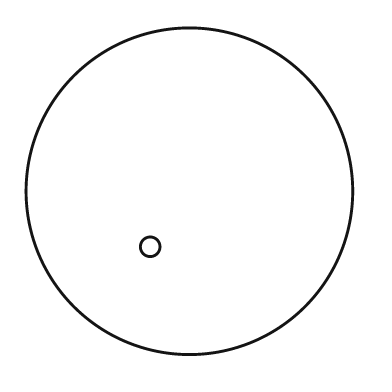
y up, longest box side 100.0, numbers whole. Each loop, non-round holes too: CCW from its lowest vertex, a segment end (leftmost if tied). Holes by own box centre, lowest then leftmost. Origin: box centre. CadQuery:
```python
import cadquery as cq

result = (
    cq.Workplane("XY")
    .moveTo(0.0, 0.0)
    .circle(50.0)
    .moveTo(-12.0, -17.0)
    .circle(3.0)
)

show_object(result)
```